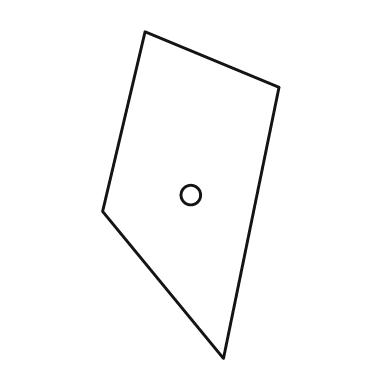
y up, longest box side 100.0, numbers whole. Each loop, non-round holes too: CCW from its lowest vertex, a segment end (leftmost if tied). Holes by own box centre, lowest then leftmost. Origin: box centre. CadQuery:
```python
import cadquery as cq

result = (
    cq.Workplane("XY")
    .moveTo(10.0, -50.0)
    .lineTo(27.0, 33.0)
    .lineTo(-14.0, 50.0)
    .lineTo(-27.0, -5.0)
    .close()
    .moveTo(0.0, 0.0)
    .circle(3.0)
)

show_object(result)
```